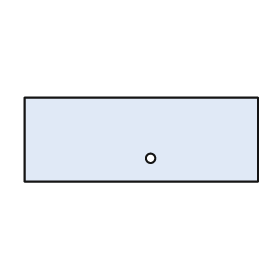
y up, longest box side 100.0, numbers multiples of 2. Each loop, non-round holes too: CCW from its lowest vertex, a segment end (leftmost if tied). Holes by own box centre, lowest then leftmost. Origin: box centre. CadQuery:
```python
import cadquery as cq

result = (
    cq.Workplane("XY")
    .moveTo(-50.0, -18.0)
    .lineTo(50.0, -18.0)
    .lineTo(50.0, 18.0)
    .lineTo(-50.0, 18.0)
    .close()
    .moveTo(4.0, -8.0)
    .circle(2.0)
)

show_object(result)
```